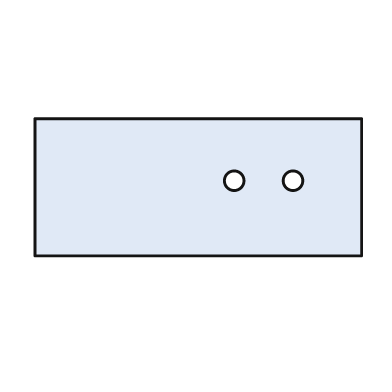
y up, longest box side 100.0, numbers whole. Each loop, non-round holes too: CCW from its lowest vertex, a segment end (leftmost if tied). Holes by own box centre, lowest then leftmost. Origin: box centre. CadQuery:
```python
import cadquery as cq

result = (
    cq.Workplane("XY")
    .moveTo(-50.0, -21.0)
    .lineTo(50.0, -21.0)
    .lineTo(50.0, 21.0)
    .lineTo(-50.0, 21.0)
    .close()
    .moveTo(11.0, 2.0)
    .circle(3.0)
    .moveTo(29.0, 2.0)
    .circle(3.0)
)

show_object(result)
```